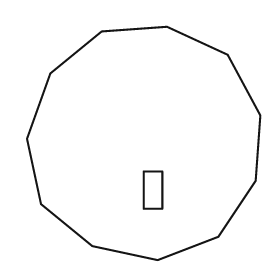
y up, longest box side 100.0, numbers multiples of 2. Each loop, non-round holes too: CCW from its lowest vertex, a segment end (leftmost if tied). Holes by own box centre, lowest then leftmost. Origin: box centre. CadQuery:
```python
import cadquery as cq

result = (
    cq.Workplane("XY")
    .moveTo(6.0, -50.0)
    .lineTo(32.0, -40.0)
    .lineTo(48.0, -16.0)
    .lineTo(50.0, 12.0)
    .lineTo(36.0, 38.0)
    .lineTo(10.0, 50.0)
    .lineTo(-18.0, 48.0)
    .lineTo(-40.0, 30.0)
    .lineTo(-50.0, 2.0)
    .lineTo(-44.0, -26.0)
    .lineTo(-22.0, -44.0)
    .close()
    .moveTo(0.0, -28.0)
    .lineTo(8.0, -28.0)
    .lineTo(8.0, -12.0)
    .lineTo(0.0, -12.0)
    .close()
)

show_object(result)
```